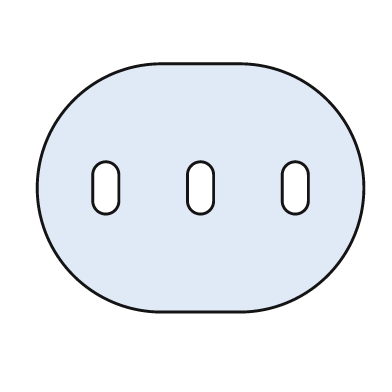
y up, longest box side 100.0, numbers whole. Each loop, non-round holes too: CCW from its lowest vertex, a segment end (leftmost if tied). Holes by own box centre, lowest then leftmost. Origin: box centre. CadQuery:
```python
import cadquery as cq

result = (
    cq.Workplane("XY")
    .moveTo(-12.0, -38.0)
    .lineTo(12.0, -38.0)
    .threePointArc((50.0, 0.0), (12.0, 38.0))
    .lineTo(-12.0, 38.0)
    .threePointArc((-50.0, 0.0), (-12.0, -38.0))
    .close()
    .moveTo(-33.0, -4.0)
    .threePointArc((-29.0, -8.0), (-25.0, -4.0))
    .lineTo(-25.0, 4.0)
    .threePointArc((-29.0, 8.0), (-33.0, 4.0))
    .close()
    .moveTo(-4.0, -4.0)
    .threePointArc((0.0, -8.0), (4.0, -4.0))
    .lineTo(4.0, 4.0)
    .threePointArc((0.0, 8.0), (-4.0, 4.0))
    .close()
    .moveTo(25.0, -4.0)
    .threePointArc((29.0, -8.0), (33.0, -4.0))
    .lineTo(33.0, 4.0)
    .threePointArc((29.0, 8.0), (25.0, 4.0))
    .close()
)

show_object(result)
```